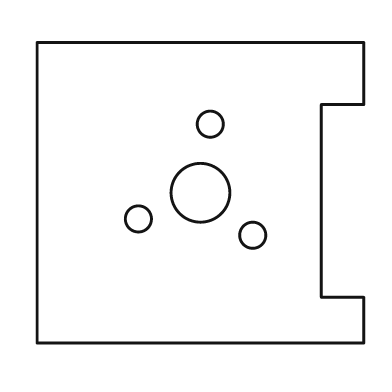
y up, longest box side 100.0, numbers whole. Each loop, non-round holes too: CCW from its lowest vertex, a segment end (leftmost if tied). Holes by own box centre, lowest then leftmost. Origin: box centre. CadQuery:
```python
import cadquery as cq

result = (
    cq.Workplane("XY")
    .moveTo(-50.0, -46.0)
    .lineTo(50.0, -46.0)
    .lineTo(50.0, -32.0)
    .lineTo(37.0, -32.0)
    .lineTo(37.0, 27.0)
    .lineTo(50.0, 27.0)
    .lineTo(50.0, 46.0)
    .lineTo(-50.0, 46.0)
    .close()
    .moveTo(16.0, -13.0)
    .circle(4.0)
    .moveTo(-19.0, -8.0)
    .circle(4.0)
    .moveTo(0.0, 0.0)
    .circle(9.0)
    .moveTo(3.0, 21.0)
    .circle(4.0)
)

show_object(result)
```